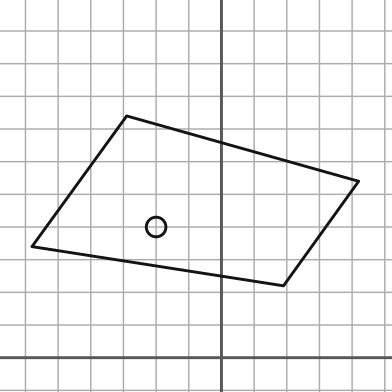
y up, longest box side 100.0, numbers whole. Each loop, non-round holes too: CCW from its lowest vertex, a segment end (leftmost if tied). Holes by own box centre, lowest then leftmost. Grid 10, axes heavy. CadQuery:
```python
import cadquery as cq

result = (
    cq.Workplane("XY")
    .moveTo(19.0, 22.0)
    .lineTo(42.0, 54.0)
    .lineTo(-29.0, 74.0)
    .lineTo(-58.0, 34.0)
    .close()
    .moveTo(-20.0, 40.0)
    .circle(3.0)
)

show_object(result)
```